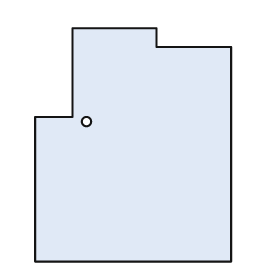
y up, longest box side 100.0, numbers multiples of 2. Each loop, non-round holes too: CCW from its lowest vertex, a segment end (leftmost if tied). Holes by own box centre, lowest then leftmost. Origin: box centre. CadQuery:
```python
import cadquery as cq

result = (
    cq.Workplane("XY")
    .moveTo(-42.0, -50.0)
    .lineTo(42.0, -50.0)
    .lineTo(42.0, 42.0)
    .lineTo(10.0, 42.0)
    .lineTo(10.0, 50.0)
    .lineTo(-26.0, 50.0)
    .lineTo(-26.0, 12.0)
    .lineTo(-42.0, 12.0)
    .close()
    .moveTo(-20.0, 10.0)
    .circle(2.0)
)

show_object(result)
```